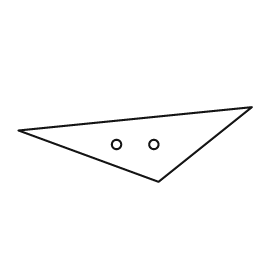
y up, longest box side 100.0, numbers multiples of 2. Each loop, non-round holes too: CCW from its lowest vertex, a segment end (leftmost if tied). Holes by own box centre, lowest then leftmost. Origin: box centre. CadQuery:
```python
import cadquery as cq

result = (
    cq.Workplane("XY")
    .moveTo(10.0, -16.0)
    .lineTo(50.0, 16.0)
    .lineTo(-50.0, 6.0)
    .close()
    .moveTo(-8.0, 0.0)
    .circle(2.0)
    .moveTo(8.0, 0.0)
    .circle(2.0)
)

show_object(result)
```